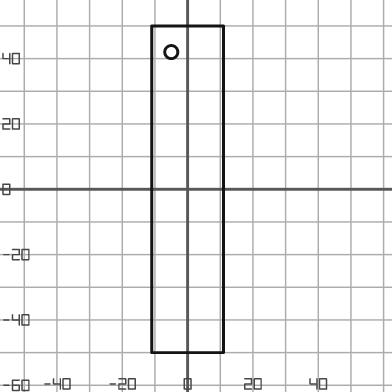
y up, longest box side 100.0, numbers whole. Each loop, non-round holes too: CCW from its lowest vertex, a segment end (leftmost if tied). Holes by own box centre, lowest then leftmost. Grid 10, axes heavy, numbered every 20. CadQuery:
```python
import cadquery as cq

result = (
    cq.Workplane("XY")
    .moveTo(-11.0, -50.0)
    .lineTo(11.0, -50.0)
    .lineTo(11.0, 50.0)
    .lineTo(-11.0, 50.0)
    .close()
    .moveTo(-5.0, 42.0)
    .circle(2.0)
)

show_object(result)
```